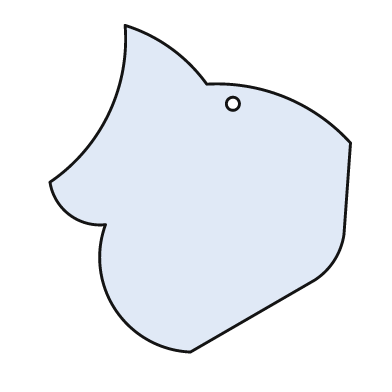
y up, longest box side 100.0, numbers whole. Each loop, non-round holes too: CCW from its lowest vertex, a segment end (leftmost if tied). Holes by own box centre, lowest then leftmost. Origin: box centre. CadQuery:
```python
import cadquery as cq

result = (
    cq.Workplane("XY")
    .moveTo(-3.0, -50.0)
    .lineTo(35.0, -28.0)
    .threePointArc((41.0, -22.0), (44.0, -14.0))
    .lineTo(46.0, 14.0)
    .threePointArc((26.0, 28.0), (2.0, 32.0))
    .threePointArc((-9.0, 43.0), (-23.0, 50.0))
    .threePointArc((-28.0, 23.0), (-46.0, 2.0))
    .threePointArc((-40.0, -8.0), (-29.0, -11.0))
    .threePointArc((-26.0, -37.0), (-3.0, -50.0))
    .close()
    .moveTo(10.0, 26.0)
    .circle(2.0)
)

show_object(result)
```